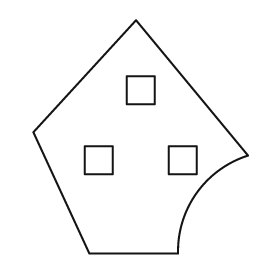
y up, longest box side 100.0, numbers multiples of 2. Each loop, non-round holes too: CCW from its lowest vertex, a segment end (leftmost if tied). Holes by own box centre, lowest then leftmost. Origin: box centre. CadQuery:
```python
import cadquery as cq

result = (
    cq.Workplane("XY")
    .moveTo(-22.0, -50.0)
    .lineTo(16.0, -50.0)
    .threePointArc((24.0, -24.0), (46.0, -8.0))
    .lineTo(-2.0, 50.0)
    .lineTo(-46.0, 2.0)
    .close()
    .moveTo(-24.0, -16.0)
    .lineTo(-12.0, -16.0)
    .lineTo(-12.0, -4.0)
    .lineTo(-24.0, -4.0)
    .close()
    .moveTo(12.0, -16.0)
    .lineTo(24.0, -16.0)
    .lineTo(24.0, -4.0)
    .lineTo(12.0, -4.0)
    .close()
    .moveTo(-6.0, 14.0)
    .lineTo(6.0, 14.0)
    .lineTo(6.0, 26.0)
    .lineTo(-6.0, 26.0)
    .close()
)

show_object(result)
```